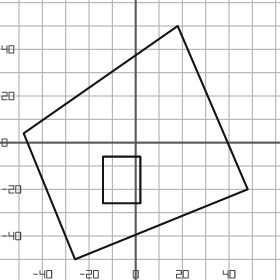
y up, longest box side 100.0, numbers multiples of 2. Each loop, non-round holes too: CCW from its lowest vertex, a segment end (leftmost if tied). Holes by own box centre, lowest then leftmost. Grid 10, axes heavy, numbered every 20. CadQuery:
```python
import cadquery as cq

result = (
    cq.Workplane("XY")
    .moveTo(-26.0, -50.0)
    .lineTo(48.0, -20.0)
    .lineTo(18.0, 50.0)
    .lineTo(-48.0, 4.0)
    .close()
    .moveTo(-14.0, -26.0)
    .lineTo(2.0, -26.0)
    .lineTo(2.0, -6.0)
    .lineTo(-14.0, -6.0)
    .close()
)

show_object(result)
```